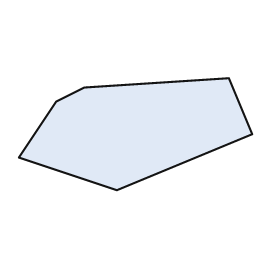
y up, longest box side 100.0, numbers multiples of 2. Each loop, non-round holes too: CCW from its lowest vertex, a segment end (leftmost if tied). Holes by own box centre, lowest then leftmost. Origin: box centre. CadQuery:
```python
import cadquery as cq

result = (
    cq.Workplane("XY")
    .moveTo(-8.0, -24.0)
    .lineTo(50.0, 0.0)
    .lineTo(40.0, 24.0)
    .lineTo(-22.0, 20.0)
    .lineTo(-34.0, 14.0)
    .lineTo(-50.0, -10.0)
    .close()
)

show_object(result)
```